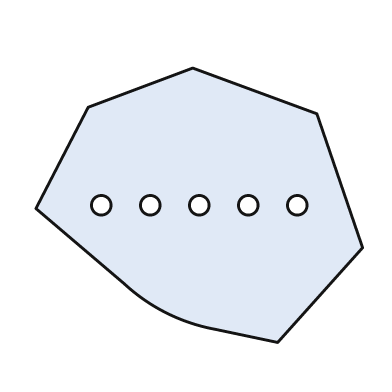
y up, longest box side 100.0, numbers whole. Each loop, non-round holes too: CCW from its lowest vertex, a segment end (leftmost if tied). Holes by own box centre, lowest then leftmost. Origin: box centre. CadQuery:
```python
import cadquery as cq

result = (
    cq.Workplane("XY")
    .moveTo(24.0, -42.0)
    .lineTo(50.0, -13.0)
    .lineTo(36.0, 28.0)
    .lineTo(-2.0, 42.0)
    .lineTo(-34.0, 30.0)
    .lineTo(-50.0, -1.0)
    .lineTo(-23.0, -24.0)
    .threePointArc((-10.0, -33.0), (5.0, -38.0))
    .close()
    .moveTo(-30.0, 0.0)
    .circle(3.0)
    .moveTo(-15.0, 0.0)
    .circle(3.0)
    .moveTo(0.0, 0.0)
    .circle(3.0)
    .moveTo(15.0, 0.0)
    .circle(3.0)
    .moveTo(30.0, 0.0)
    .circle(3.0)
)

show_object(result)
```